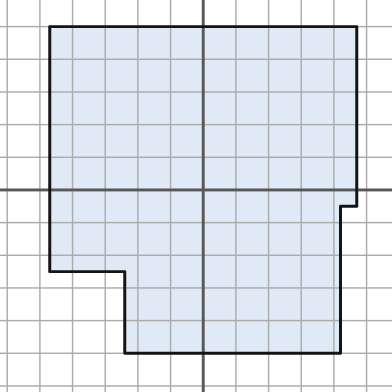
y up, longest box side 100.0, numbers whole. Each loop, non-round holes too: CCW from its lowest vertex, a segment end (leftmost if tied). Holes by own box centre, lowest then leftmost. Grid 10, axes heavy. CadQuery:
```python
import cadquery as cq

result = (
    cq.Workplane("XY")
    .moveTo(-24.0, -50.0)
    .lineTo(42.0, -50.0)
    .lineTo(42.0, -5.0)
    .lineTo(47.0, -5.0)
    .lineTo(47.0, 50.0)
    .lineTo(-47.0, 50.0)
    .lineTo(-47.0, -25.0)
    .lineTo(-24.0, -25.0)
    .close()
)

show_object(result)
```